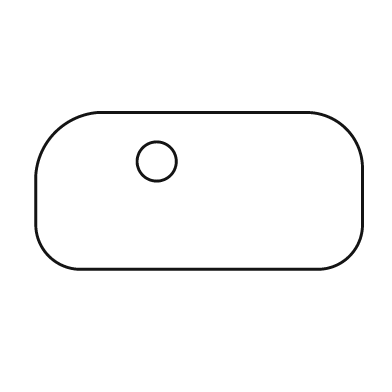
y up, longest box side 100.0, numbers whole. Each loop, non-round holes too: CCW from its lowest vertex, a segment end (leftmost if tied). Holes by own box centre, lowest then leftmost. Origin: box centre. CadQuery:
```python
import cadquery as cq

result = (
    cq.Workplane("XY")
    .moveTo(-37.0, -24.0)
    .lineTo(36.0, -24.0)
    .threePointArc((46.0, -20.0), (50.0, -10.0))
    .lineTo(50.0, 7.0)
    .threePointArc((45.0, 19.0), (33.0, 24.0))
    .lineTo(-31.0, 24.0)
    .threePointArc((-44.0, 18.0), (-50.0, 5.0))
    .lineTo(-50.0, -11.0)
    .threePointArc((-46.0, -20.0), (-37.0, -24.0))
    .close()
    .moveTo(-13.0, 9.0)
    .circle(6.0)
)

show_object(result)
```